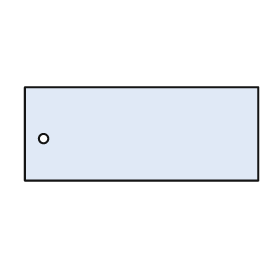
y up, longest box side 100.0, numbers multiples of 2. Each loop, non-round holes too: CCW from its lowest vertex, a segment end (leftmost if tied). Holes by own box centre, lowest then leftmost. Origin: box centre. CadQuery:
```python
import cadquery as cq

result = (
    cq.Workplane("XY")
    .moveTo(-50.0, -20.0)
    .lineTo(50.0, -20.0)
    .lineTo(50.0, 20.0)
    .lineTo(-50.0, 20.0)
    .close()
    .moveTo(-42.0, -2.0)
    .circle(2.0)
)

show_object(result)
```